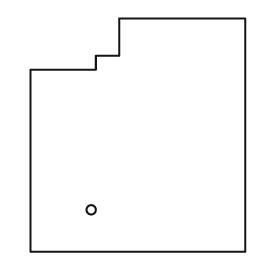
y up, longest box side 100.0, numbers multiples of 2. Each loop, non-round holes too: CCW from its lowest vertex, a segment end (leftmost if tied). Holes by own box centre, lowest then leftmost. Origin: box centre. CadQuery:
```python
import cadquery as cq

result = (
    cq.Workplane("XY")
    .moveTo(-46.0, -50.0)
    .lineTo(46.0, -50.0)
    .lineTo(46.0, 50.0)
    .lineTo(-8.0, 50.0)
    .lineTo(-8.0, 34.0)
    .lineTo(-18.0, 34.0)
    .lineTo(-18.0, 28.0)
    .lineTo(-46.0, 28.0)
    .close()
    .moveTo(-20.0, -32.0)
    .circle(2.0)
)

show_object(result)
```